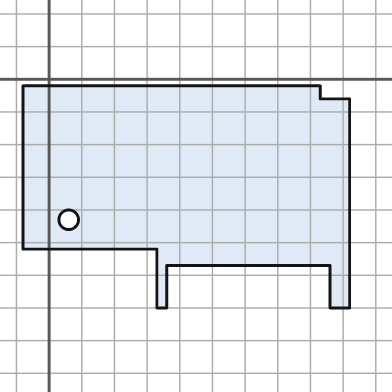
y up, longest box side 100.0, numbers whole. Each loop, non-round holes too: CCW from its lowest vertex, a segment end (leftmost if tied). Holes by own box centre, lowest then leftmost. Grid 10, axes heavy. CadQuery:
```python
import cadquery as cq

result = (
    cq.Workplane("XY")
    .moveTo(33.0, -70.0)
    .lineTo(36.0, -70.0)
    .lineTo(36.0, -57.0)
    .lineTo(86.0, -57.0)
    .lineTo(86.0, -70.0)
    .lineTo(92.0, -70.0)
    .lineTo(92.0, -6.0)
    .lineTo(83.0, -6.0)
    .lineTo(83.0, -2.0)
    .lineTo(-8.0, -2.0)
    .lineTo(-8.0, -52.0)
    .lineTo(33.0, -52.0)
    .close()
    .moveTo(6.0, -43.0)
    .circle(3.0)
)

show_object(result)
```